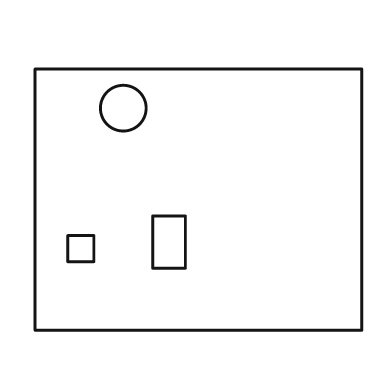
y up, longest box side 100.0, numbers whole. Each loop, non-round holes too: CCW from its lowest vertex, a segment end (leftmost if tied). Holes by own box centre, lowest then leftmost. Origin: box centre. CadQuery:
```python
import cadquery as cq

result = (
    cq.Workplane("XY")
    .moveTo(-50.0, -40.0)
    .lineTo(50.0, -40.0)
    .lineTo(50.0, 40.0)
    .lineTo(-50.0, 40.0)
    .close()
    .moveTo(-40.0, -19.0)
    .lineTo(-32.0, -19.0)
    .lineTo(-32.0, -11.0)
    .lineTo(-40.0, -11.0)
    .close()
    .moveTo(-14.0, -21.0)
    .lineTo(-4.0, -21.0)
    .lineTo(-4.0, -5.0)
    .lineTo(-14.0, -5.0)
    .close()
    .moveTo(-23.0, 28.0)
    .circle(7.0)
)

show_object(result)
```